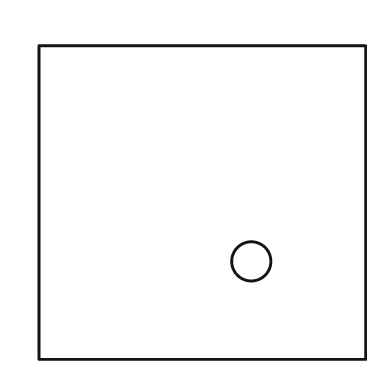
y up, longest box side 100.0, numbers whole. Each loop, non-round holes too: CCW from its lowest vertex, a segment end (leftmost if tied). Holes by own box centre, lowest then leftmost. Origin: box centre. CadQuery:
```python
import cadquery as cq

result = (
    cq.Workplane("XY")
    .moveTo(-50.0, -48.0)
    .lineTo(50.0, -48.0)
    .lineTo(50.0, 48.0)
    .lineTo(-50.0, 48.0)
    .close()
    .moveTo(15.0, -18.0)
    .circle(6.0)
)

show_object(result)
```